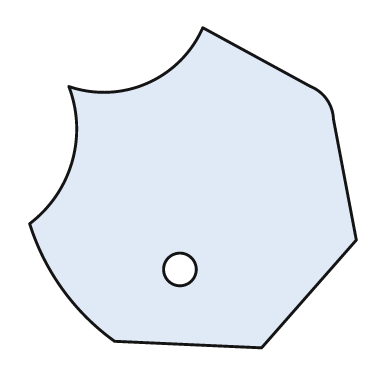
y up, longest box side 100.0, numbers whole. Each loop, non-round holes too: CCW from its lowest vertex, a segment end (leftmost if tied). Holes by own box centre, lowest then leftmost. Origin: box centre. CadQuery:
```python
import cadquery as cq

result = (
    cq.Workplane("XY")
    .moveTo(21.0, -49.0)
    .lineTo(50.0, -16.0)
    .lineTo(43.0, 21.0)
    .threePointArc((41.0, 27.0), (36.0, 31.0))
    .lineTo(3.0, 49.0)
    .threePointArc((-14.0, 32.0), (-38.0, 31.0))
    .threePointArc((-37.0, 8.0), (-50.0, -11.0))
    .threePointArc((-40.0, -31.0), (-24.0, -47.0))
    .close()
    .moveTo(-4.0, -25.0)
    .circle(5.0)
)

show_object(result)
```